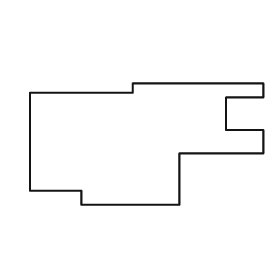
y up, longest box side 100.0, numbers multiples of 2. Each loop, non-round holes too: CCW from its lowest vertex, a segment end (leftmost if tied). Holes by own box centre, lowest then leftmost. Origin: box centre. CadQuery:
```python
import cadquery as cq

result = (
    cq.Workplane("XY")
    .moveTo(-28.0, -26.0)
    .lineTo(14.0, -26.0)
    .lineTo(14.0, -4.0)
    .lineTo(50.0, -4.0)
    .lineTo(50.0, 6.0)
    .lineTo(34.0, 6.0)
    .lineTo(34.0, 20.0)
    .lineTo(50.0, 20.0)
    .lineTo(50.0, 26.0)
    .lineTo(-6.0, 26.0)
    .lineTo(-6.0, 22.0)
    .lineTo(-50.0, 22.0)
    .lineTo(-50.0, -20.0)
    .lineTo(-28.0, -20.0)
    .close()
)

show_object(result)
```